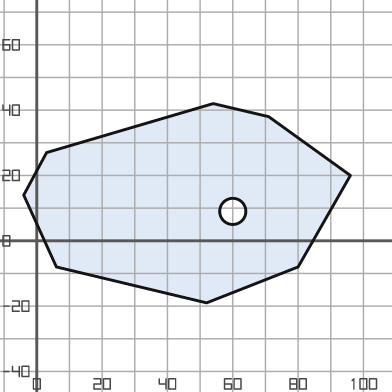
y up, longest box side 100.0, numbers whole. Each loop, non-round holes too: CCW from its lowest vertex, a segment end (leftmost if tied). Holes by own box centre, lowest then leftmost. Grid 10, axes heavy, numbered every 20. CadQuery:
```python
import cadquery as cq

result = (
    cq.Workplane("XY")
    .moveTo(52.0, -19.0)
    .lineTo(80.0, -8.0)
    .lineTo(96.0, 20.0)
    .lineTo(71.0, 38.0)
    .lineTo(54.0, 42.0)
    .lineTo(3.0, 27.0)
    .lineTo(-4.0, 14.0)
    .lineTo(6.0, -8.0)
    .close()
    .moveTo(60.0, 9.0)
    .circle(4.0)
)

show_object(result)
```